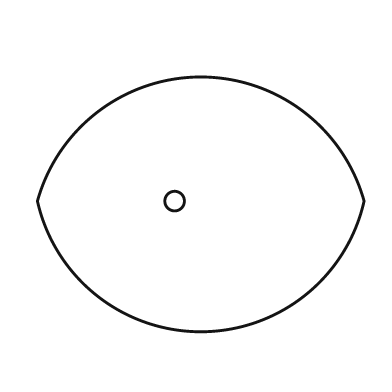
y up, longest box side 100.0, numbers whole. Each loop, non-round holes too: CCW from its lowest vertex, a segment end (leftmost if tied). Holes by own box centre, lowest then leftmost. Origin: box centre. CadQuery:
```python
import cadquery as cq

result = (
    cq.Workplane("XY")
    .moveTo(-50.0, 1.0)
    .threePointArc((0.0, -39.0), (50.0, 1.0))
    .threePointArc((0.0, 39.0), (-50.0, 1.0))
    .close()
    .moveTo(-8.0, 1.0)
    .circle(3.0)
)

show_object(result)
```